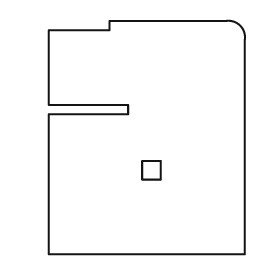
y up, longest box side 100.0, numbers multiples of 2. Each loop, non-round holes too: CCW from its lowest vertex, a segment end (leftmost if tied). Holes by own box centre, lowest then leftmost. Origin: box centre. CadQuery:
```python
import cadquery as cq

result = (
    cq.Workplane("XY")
    .moveTo(-42.0, -50.0)
    .lineTo(42.0, -50.0)
    .lineTo(42.0, 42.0)
    .threePointArc((40.0, 48.0), (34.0, 50.0))
    .lineTo(-16.0, 50.0)
    .lineTo(-16.0, 46.0)
    .lineTo(-42.0, 46.0)
    .lineTo(-42.0, 14.0)
    .lineTo(-8.0, 14.0)
    .lineTo(-8.0, 10.0)
    .lineTo(-42.0, 10.0)
    .close()
    .moveTo(-2.0, -18.0)
    .lineTo(6.0, -18.0)
    .lineTo(6.0, -10.0)
    .lineTo(-2.0, -10.0)
    .close()
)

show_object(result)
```